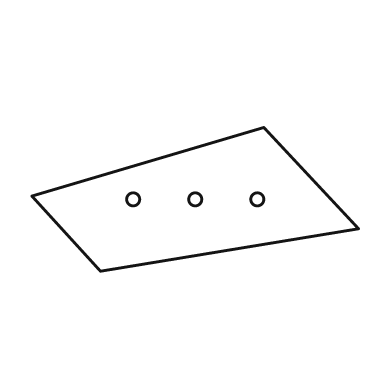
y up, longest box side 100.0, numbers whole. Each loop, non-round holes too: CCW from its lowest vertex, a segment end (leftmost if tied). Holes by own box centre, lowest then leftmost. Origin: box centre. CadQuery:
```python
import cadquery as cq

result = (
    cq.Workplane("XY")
    .moveTo(-29.0, -22.0)
    .lineTo(50.0, -9.0)
    .lineTo(21.0, 22.0)
    .lineTo(-50.0, 1.0)
    .close()
    .moveTo(-19.0, 0.0)
    .circle(2.0)
    .moveTo(0.0, 0.0)
    .circle(2.0)
    .moveTo(19.0, 0.0)
    .circle(2.0)
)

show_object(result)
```